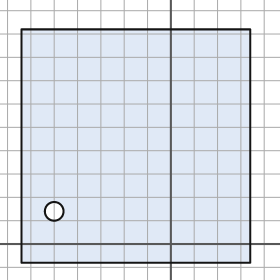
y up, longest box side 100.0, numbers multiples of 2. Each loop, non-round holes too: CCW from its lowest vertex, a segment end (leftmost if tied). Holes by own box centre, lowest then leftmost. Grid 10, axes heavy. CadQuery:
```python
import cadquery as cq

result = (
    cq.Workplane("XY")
    .moveTo(-64.0, -8.0)
    .lineTo(34.0, -8.0)
    .lineTo(34.0, 92.0)
    .lineTo(-64.0, 92.0)
    .close()
    .moveTo(-50.0, 14.0)
    .circle(4.0)
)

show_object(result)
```